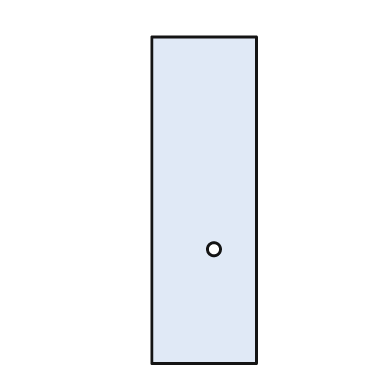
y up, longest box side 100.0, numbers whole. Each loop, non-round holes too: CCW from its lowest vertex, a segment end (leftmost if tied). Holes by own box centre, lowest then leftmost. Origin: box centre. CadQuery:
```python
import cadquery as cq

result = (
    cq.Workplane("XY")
    .moveTo(-16.0, -50.0)
    .lineTo(16.0, -50.0)
    .lineTo(16.0, 50.0)
    .lineTo(-16.0, 50.0)
    .close()
    .moveTo(3.0, -15.0)
    .circle(2.0)
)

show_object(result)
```